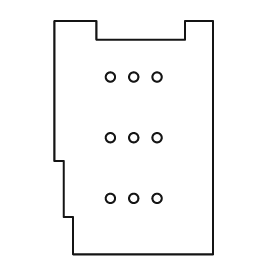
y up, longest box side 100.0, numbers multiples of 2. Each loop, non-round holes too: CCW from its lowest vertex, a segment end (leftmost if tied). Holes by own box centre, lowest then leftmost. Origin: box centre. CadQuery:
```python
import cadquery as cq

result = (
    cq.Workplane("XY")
    .moveTo(-26.0, -50.0)
    .lineTo(34.0, -50.0)
    .lineTo(34.0, 50.0)
    .lineTo(22.0, 50.0)
    .lineTo(22.0, 42.0)
    .lineTo(-16.0, 42.0)
    .lineTo(-16.0, 50.0)
    .lineTo(-34.0, 50.0)
    .lineTo(-34.0, -10.0)
    .lineTo(-30.0, -10.0)
    .lineTo(-30.0, -34.0)
    .lineTo(-26.0, -34.0)
    .close()
    .moveTo(-10.0, -26.0)
    .circle(2.0)
    .moveTo(0.0, -26.0)
    .circle(2.0)
    .moveTo(10.0, -26.0)
    .circle(2.0)
    .moveTo(-10.0, 0.0)
    .circle(2.0)
    .moveTo(0.0, 0.0)
    .circle(2.0)
    .moveTo(10.0, 0.0)
    .circle(2.0)
    .moveTo(-10.0, 26.0)
    .circle(2.0)
    .moveTo(0.0, 26.0)
    .circle(2.0)
    .moveTo(10.0, 26.0)
    .circle(2.0)
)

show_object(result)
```